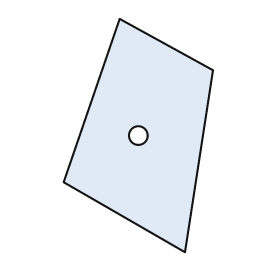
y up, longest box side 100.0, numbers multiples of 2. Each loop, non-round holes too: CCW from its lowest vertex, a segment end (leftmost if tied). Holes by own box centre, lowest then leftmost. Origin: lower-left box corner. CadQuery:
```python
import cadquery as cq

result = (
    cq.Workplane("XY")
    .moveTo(52.0, 0.0)
    .lineTo(64.0, 78.0)
    .lineTo(24.0, 100.0)
    .lineTo(0.0, 30.0)
    .close()
    .moveTo(32.0, 50.0)
    .circle(4.0)
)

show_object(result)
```